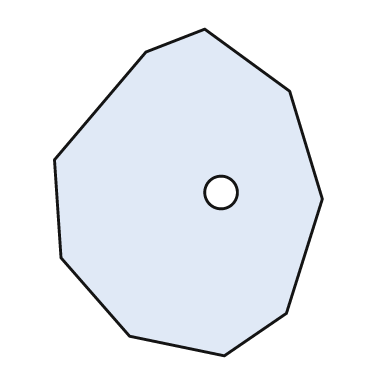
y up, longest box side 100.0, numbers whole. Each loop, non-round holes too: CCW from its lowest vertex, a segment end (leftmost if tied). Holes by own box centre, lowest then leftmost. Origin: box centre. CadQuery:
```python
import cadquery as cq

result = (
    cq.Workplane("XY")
    .moveTo(11.0, -50.0)
    .lineTo(30.0, -37.0)
    .lineTo(41.0, -2.0)
    .lineTo(31.0, 31.0)
    .lineTo(5.0, 50.0)
    .lineTo(-13.0, 43.0)
    .lineTo(-41.0, 10.0)
    .lineTo(-39.0, -20.0)
    .lineTo(-18.0, -44.0)
    .close()
    .moveTo(10.0, 0.0)
    .circle(5.0)
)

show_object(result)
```